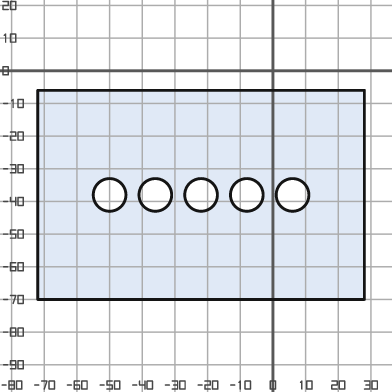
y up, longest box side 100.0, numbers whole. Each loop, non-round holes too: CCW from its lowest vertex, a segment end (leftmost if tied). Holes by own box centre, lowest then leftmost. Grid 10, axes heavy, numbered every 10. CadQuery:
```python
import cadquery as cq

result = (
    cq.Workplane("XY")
    .moveTo(-72.0, -70.0)
    .lineTo(28.0, -70.0)
    .lineTo(28.0, -6.0)
    .lineTo(-72.0, -6.0)
    .close()
    .moveTo(-50.0, -38.0)
    .circle(5.0)
    .moveTo(-36.0, -38.0)
    .circle(5.0)
    .moveTo(-22.0, -38.0)
    .circle(5.0)
    .moveTo(-8.0, -38.0)
    .circle(5.0)
    .moveTo(6.0, -38.0)
    .circle(5.0)
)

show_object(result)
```